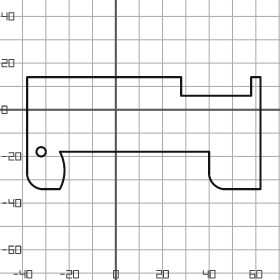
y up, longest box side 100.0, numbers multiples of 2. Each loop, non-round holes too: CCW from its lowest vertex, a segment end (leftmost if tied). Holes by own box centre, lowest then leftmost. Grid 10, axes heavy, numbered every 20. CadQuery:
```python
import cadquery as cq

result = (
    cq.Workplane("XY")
    .moveTo(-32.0, -34.0)
    .lineTo(-24.0, -34.0)
    .threePointArc((-22.0, -26.0), (-24.0, -18.0))
    .lineTo(40.0, -18.0)
    .lineTo(40.0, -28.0)
    .threePointArc((42.0, -32.0), (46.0, -34.0))
    .lineTo(62.0, -34.0)
    .lineTo(62.0, 14.0)
    .lineTo(58.0, 14.0)
    .lineTo(58.0, 6.0)
    .lineTo(28.0, 6.0)
    .lineTo(28.0, 14.0)
    .lineTo(-38.0, 14.0)
    .lineTo(-38.0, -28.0)
    .threePointArc((-36.0, -32.0), (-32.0, -34.0))
    .close()
    .moveTo(-32.0, -18.0)
    .circle(2.0)
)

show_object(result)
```